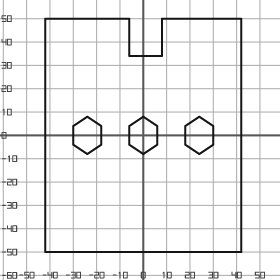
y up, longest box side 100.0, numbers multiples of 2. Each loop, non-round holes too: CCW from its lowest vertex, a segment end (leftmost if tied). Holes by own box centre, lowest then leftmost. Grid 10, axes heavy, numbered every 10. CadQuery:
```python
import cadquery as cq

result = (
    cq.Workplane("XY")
    .moveTo(-42.0, -50.0)
    .lineTo(42.0, -50.0)
    .lineTo(42.0, 50.0)
    .lineTo(8.0, 50.0)
    .lineTo(8.0, 34.0)
    .lineTo(-6.0, 34.0)
    .lineTo(-6.0, 50.0)
    .lineTo(-42.0, 50.0)
    .close()
    .moveTo(-24.0, -8.0)
    .lineTo(-18.0, -4.0)
    .lineTo(-18.0, 4.0)
    .lineTo(-24.0, 8.0)
    .lineTo(-30.0, 4.0)
    .lineTo(-30.0, -4.0)
    .close()
    .moveTo(0.0, -8.0)
    .lineTo(6.0, -4.0)
    .lineTo(6.0, 4.0)
    .lineTo(0.0, 8.0)
    .lineTo(-6.0, 4.0)
    .lineTo(-6.0, -4.0)
    .close()
    .moveTo(24.0, -8.0)
    .lineTo(30.0, -4.0)
    .lineTo(30.0, 4.0)
    .lineTo(24.0, 8.0)
    .lineTo(18.0, 4.0)
    .lineTo(18.0, -4.0)
    .close()
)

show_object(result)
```